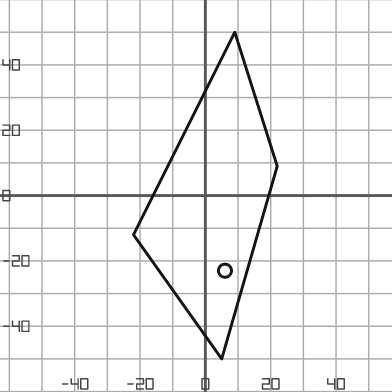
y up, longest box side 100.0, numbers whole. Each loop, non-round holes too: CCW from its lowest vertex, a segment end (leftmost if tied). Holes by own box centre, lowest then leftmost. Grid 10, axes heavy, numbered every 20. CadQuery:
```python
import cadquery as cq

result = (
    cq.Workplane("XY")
    .moveTo(5.0, -50.0)
    .lineTo(22.0, 9.0)
    .lineTo(9.0, 50.0)
    .lineTo(-22.0, -12.0)
    .close()
    .moveTo(6.0, -23.0)
    .circle(2.0)
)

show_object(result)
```